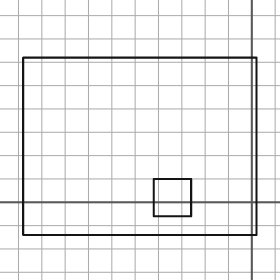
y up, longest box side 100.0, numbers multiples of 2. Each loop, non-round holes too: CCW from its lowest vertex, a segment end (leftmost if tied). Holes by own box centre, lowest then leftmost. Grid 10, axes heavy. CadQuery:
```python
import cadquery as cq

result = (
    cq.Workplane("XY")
    .moveTo(-98.0, -14.0)
    .lineTo(2.0, -14.0)
    .lineTo(2.0, 62.0)
    .lineTo(-98.0, 62.0)
    .close()
    .moveTo(-42.0, -6.0)
    .lineTo(-26.0, -6.0)
    .lineTo(-26.0, 10.0)
    .lineTo(-42.0, 10.0)
    .close()
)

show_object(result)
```